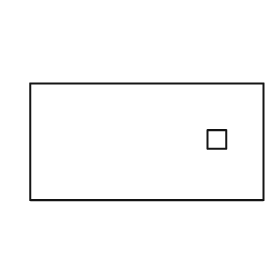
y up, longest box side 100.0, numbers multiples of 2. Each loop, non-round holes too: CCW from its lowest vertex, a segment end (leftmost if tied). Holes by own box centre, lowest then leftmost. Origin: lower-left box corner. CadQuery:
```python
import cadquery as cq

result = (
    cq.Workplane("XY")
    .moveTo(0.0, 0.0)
    .lineTo(100.0, 0.0)
    .lineTo(100.0, 50.0)
    .lineTo(0.0, 50.0)
    .close()
    .moveTo(76.0, 22.0)
    .lineTo(84.0, 22.0)
    .lineTo(84.0, 30.0)
    .lineTo(76.0, 30.0)
    .close()
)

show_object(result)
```